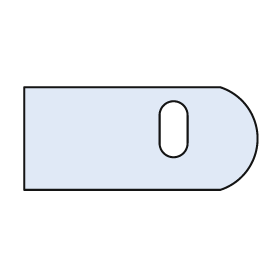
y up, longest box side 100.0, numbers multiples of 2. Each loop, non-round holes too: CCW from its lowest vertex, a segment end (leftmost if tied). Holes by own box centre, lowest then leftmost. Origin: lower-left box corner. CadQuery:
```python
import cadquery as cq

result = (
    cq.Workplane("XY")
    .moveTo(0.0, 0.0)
    .lineTo(84.0, 0.0)
    .threePointArc((100.0, 22.0), (84.0, 44.0))
    .lineTo(0.0, 44.0)
    .close()
    .moveTo(58.0, 20.0)
    .threePointArc((64.0, 14.0), (70.0, 20.0))
    .lineTo(70.0, 32.0)
    .threePointArc((64.0, 38.0), (58.0, 32.0))
    .close()
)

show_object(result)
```